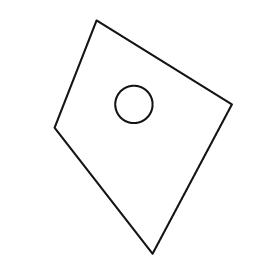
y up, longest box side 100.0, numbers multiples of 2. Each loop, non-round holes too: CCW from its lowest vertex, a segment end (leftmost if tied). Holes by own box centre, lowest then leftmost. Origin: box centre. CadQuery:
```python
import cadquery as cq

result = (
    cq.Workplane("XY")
    .moveTo(4.0, -50.0)
    .lineTo(38.0, 14.0)
    .lineTo(-20.0, 50.0)
    .lineTo(-38.0, 4.0)
    .close()
    .moveTo(-4.0, 14.0)
    .circle(8.0)
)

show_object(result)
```